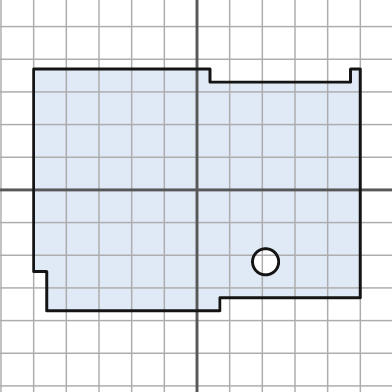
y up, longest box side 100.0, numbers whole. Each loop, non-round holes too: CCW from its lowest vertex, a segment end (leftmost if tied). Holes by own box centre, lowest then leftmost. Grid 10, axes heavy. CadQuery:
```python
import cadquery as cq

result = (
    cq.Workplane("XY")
    .moveTo(-46.0, -37.0)
    .lineTo(7.0, -37.0)
    .lineTo(7.0, -33.0)
    .lineTo(50.0, -33.0)
    .lineTo(50.0, 37.0)
    .lineTo(47.0, 37.0)
    .lineTo(47.0, 33.0)
    .lineTo(4.0, 33.0)
    .lineTo(4.0, 37.0)
    .lineTo(-50.0, 37.0)
    .lineTo(-50.0, -25.0)
    .lineTo(-46.0, -25.0)
    .close()
    .moveTo(21.0, -22.0)
    .circle(4.0)
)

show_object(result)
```